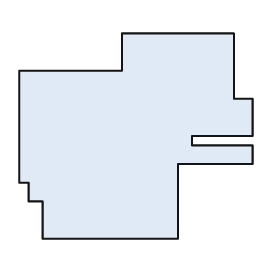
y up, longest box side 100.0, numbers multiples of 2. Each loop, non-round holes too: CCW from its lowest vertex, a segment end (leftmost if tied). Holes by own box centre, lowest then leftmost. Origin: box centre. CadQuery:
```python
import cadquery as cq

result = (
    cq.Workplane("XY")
    .moveTo(-40.0, -44.0)
    .lineTo(18.0, -44.0)
    .lineTo(18.0, -12.0)
    .lineTo(50.0, -12.0)
    .lineTo(50.0, -4.0)
    .lineTo(24.0, -4.0)
    .lineTo(24.0, 0.0)
    .lineTo(50.0, 0.0)
    .lineTo(50.0, 16.0)
    .lineTo(42.0, 16.0)
    .lineTo(42.0, 44.0)
    .lineTo(-6.0, 44.0)
    .lineTo(-6.0, 28.0)
    .lineTo(-50.0, 28.0)
    .lineTo(-50.0, -20.0)
    .lineTo(-46.0, -20.0)
    .lineTo(-46.0, -28.0)
    .lineTo(-40.0, -28.0)
    .close()
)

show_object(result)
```